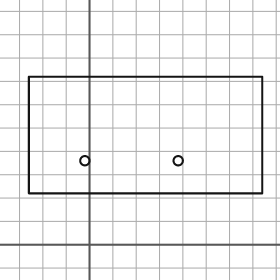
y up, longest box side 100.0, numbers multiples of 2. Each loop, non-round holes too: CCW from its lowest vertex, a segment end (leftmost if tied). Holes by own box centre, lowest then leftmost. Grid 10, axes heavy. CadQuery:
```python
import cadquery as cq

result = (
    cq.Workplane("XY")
    .moveTo(-26.0, 22.0)
    .lineTo(74.0, 22.0)
    .lineTo(74.0, 72.0)
    .lineTo(-26.0, 72.0)
    .close()
    .moveTo(-2.0, 36.0)
    .circle(2.0)
    .moveTo(38.0, 36.0)
    .circle(2.0)
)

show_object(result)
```